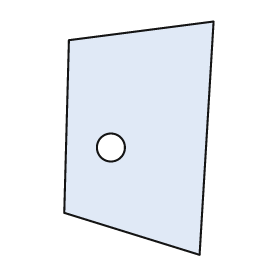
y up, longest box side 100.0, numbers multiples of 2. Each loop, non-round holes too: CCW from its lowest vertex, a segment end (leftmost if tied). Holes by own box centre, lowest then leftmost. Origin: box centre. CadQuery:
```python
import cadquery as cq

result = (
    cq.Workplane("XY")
    .moveTo(26.0, -50.0)
    .lineTo(32.0, 50.0)
    .lineTo(-30.0, 42.0)
    .lineTo(-32.0, -32.0)
    .close()
    .moveTo(-12.0, -4.0)
    .circle(6.0)
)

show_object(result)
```